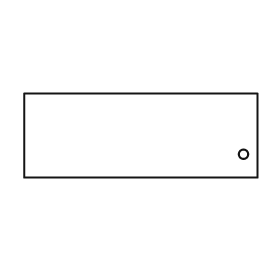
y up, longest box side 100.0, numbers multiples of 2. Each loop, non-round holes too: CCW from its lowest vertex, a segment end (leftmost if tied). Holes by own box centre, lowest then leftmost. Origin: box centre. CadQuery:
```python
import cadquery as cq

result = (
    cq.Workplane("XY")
    .moveTo(-50.0, -18.0)
    .lineTo(50.0, -18.0)
    .lineTo(50.0, 18.0)
    .lineTo(-50.0, 18.0)
    .close()
    .moveTo(44.0, -8.0)
    .circle(2.0)
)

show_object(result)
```